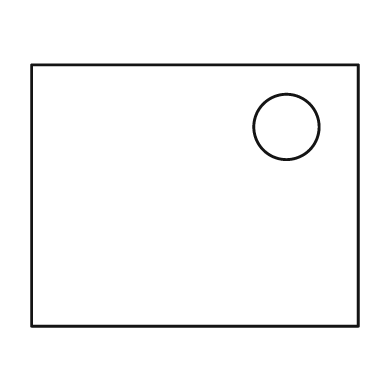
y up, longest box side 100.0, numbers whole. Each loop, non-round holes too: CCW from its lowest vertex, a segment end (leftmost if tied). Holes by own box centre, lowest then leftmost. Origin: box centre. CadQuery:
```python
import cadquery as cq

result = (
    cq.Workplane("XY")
    .moveTo(-50.0, -40.0)
    .lineTo(50.0, -40.0)
    .lineTo(50.0, 40.0)
    .lineTo(-50.0, 40.0)
    .close()
    .moveTo(28.0, 21.0)
    .circle(10.0)
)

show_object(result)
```